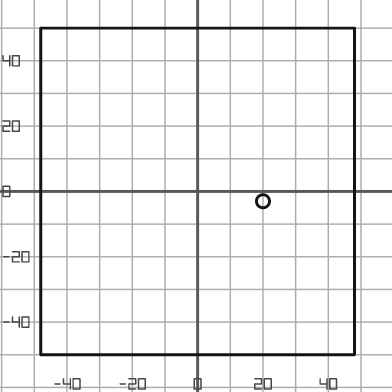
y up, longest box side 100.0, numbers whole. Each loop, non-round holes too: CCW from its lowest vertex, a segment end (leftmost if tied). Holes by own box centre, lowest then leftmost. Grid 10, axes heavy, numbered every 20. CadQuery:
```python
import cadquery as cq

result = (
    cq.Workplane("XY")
    .moveTo(-48.0, -50.0)
    .lineTo(48.0, -50.0)
    .lineTo(48.0, 50.0)
    .lineTo(-48.0, 50.0)
    .close()
    .moveTo(20.0, -3.0)
    .circle(2.0)
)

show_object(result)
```